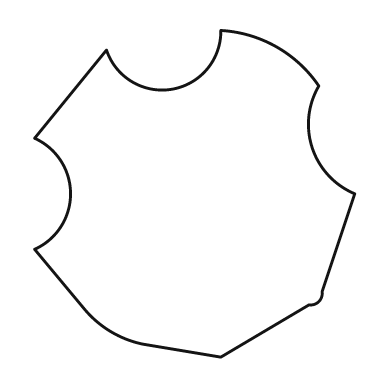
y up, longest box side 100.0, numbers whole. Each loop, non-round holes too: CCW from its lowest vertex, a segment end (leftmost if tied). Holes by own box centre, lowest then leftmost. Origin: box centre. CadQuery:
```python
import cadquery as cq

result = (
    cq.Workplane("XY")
    .moveTo(8.0, -50.0)
    .lineTo(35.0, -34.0)
    .threePointArc((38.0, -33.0), (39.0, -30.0))
    .lineTo(49.0, 0.0)
    .threePointArc((36.0, 14.0), (38.0, 33.0))
    .threePointArc((25.0, 45.0), (8.0, 50.0))
    .threePointArc((-7.0, 32.0), (-27.0, 44.0))
    .lineTo(-49.0, 17.0)
    .threePointArc((-38.0, 0.0), (-49.0, -17.0))
    .lineTo(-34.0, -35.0)
    .threePointArc((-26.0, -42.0), (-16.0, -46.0))
    .close()
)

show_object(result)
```